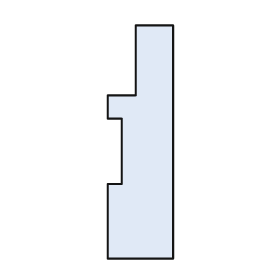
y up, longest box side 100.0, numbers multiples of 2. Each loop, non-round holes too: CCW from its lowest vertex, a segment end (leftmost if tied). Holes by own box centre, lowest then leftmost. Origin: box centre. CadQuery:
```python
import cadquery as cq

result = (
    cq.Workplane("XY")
    .moveTo(-14.0, -50.0)
    .lineTo(14.0, -50.0)
    .lineTo(14.0, 50.0)
    .lineTo(-2.0, 50.0)
    .lineTo(-2.0, 20.0)
    .lineTo(-14.0, 20.0)
    .lineTo(-14.0, 10.0)
    .lineTo(-8.0, 10.0)
    .lineTo(-8.0, -18.0)
    .lineTo(-14.0, -18.0)
    .close()
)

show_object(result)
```